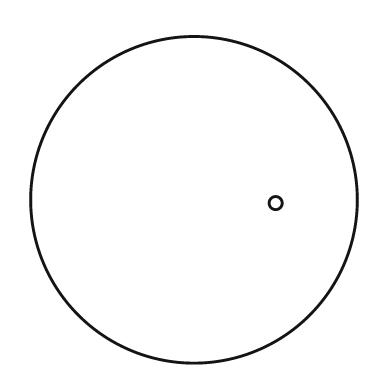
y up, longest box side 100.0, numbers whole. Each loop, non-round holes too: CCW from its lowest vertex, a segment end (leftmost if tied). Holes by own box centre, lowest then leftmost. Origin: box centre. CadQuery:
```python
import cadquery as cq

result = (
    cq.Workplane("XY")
    .moveTo(0.0, 0.0)
    .circle(50.0)
    .moveTo(25.0, -1.0)
    .circle(2.0)
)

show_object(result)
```